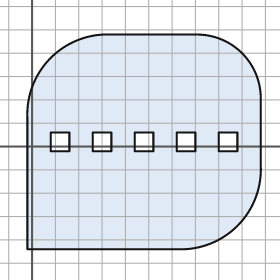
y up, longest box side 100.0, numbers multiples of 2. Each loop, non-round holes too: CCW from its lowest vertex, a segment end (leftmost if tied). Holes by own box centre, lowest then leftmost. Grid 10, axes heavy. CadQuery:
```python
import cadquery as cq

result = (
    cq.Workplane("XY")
    .moveTo(-2.0, -44.0)
    .lineTo(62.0, -44.0)
    .threePointArc((88.0, -34.0), (98.0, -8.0))
    .lineTo(98.0, 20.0)
    .threePointArc((90.0, 40.0), (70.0, 48.0))
    .lineTo(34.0, 48.0)
    .threePointArc((8.0, 38.0), (-2.0, 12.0))
    .close()
    .moveTo(8.0, -2.0)
    .lineTo(16.0, -2.0)
    .lineTo(16.0, 6.0)
    .lineTo(8.0, 6.0)
    .close()
    .moveTo(26.0, -2.0)
    .lineTo(34.0, -2.0)
    .lineTo(34.0, 6.0)
    .lineTo(26.0, 6.0)
    .close()
    .moveTo(44.0, -2.0)
    .lineTo(52.0, -2.0)
    .lineTo(52.0, 6.0)
    .lineTo(44.0, 6.0)
    .close()
    .moveTo(62.0, -2.0)
    .lineTo(70.0, -2.0)
    .lineTo(70.0, 6.0)
    .lineTo(62.0, 6.0)
    .close()
    .moveTo(80.0, -2.0)
    .lineTo(88.0, -2.0)
    .lineTo(88.0, 6.0)
    .lineTo(80.0, 6.0)
    .close()
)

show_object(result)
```